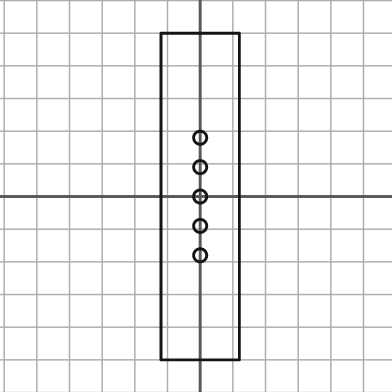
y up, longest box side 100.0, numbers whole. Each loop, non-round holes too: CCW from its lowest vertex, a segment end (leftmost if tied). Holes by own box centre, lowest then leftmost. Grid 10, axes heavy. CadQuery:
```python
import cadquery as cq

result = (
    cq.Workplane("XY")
    .moveTo(-12.0, -50.0)
    .lineTo(12.0, -50.0)
    .lineTo(12.0, 50.0)
    .lineTo(-12.0, 50.0)
    .close()
    .moveTo(0.0, -18.0)
    .circle(2.0)
    .moveTo(0.0, -9.0)
    .circle(2.0)
    .moveTo(0.0, 0.0)
    .circle(2.0)
    .moveTo(0.0, 9.0)
    .circle(2.0)
    .moveTo(0.0, 18.0)
    .circle(2.0)
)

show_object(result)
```